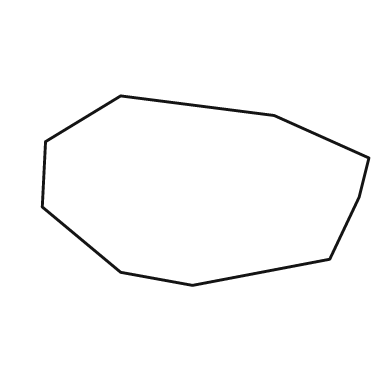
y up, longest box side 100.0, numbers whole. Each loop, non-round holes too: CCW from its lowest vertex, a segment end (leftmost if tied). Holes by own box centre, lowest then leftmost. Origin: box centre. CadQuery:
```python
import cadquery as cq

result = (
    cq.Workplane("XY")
    .moveTo(-4.0, -29.0)
    .lineTo(38.0, -21.0)
    .lineTo(47.0, -2.0)
    .lineTo(50.0, 10.0)
    .lineTo(21.0, 23.0)
    .lineTo(-26.0, 29.0)
    .lineTo(-49.0, 15.0)
    .lineTo(-50.0, -5.0)
    .lineTo(-26.0, -25.0)
    .close()
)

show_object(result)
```